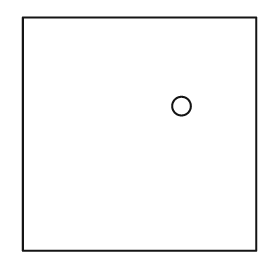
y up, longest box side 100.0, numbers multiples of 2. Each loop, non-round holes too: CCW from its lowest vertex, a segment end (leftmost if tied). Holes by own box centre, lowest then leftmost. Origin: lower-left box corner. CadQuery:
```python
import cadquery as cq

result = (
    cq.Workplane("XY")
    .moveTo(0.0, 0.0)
    .lineTo(100.0, 0.0)
    .lineTo(100.0, 100.0)
    .lineTo(0.0, 100.0)
    .close()
    .moveTo(68.0, 62.0)
    .circle(4.0)
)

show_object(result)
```